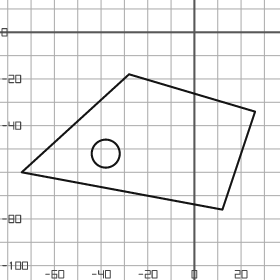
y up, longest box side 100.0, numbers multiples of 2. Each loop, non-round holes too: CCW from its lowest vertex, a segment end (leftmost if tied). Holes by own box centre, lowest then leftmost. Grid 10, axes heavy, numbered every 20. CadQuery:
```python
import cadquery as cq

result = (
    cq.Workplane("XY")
    .moveTo(12.0, -76.0)
    .lineTo(26.0, -34.0)
    .lineTo(-28.0, -18.0)
    .lineTo(-74.0, -60.0)
    .close()
    .moveTo(-38.0, -52.0)
    .circle(6.0)
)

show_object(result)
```